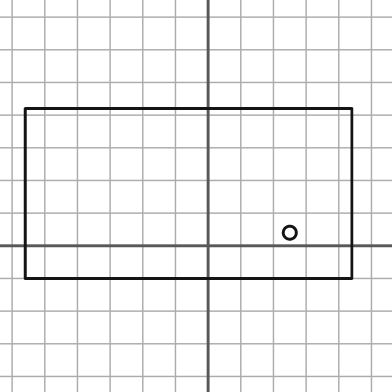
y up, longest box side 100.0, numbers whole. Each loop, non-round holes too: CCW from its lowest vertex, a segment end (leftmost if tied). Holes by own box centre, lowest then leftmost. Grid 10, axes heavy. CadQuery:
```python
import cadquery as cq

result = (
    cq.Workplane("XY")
    .moveTo(-56.0, -10.0)
    .lineTo(44.0, -10.0)
    .lineTo(44.0, 42.0)
    .lineTo(-56.0, 42.0)
    .close()
    .moveTo(25.0, 4.0)
    .circle(2.0)
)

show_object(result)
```